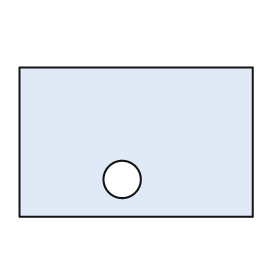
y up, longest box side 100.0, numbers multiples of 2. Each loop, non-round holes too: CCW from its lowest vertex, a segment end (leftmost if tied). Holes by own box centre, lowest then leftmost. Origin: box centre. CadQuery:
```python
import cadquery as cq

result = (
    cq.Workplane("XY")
    .moveTo(-50.0, -32.0)
    .lineTo(50.0, -32.0)
    .lineTo(50.0, 32.0)
    .lineTo(-50.0, 32.0)
    .close()
    .moveTo(-6.0, -16.0)
    .circle(8.0)
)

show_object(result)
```